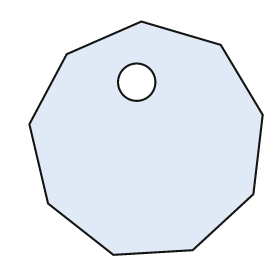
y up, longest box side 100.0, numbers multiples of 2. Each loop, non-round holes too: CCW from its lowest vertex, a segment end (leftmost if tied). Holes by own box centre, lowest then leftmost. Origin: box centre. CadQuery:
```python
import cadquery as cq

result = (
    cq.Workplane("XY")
    .moveTo(-14.0, -50.0)
    .lineTo(20.0, -48.0)
    .lineTo(46.0, -24.0)
    .lineTo(50.0, 10.0)
    .lineTo(32.0, 40.0)
    .lineTo(-2.0, 50.0)
    .lineTo(-34.0, 36.0)
    .lineTo(-50.0, 6.0)
    .lineTo(-42.0, -28.0)
    .close()
    .moveTo(-4.0, 24.0)
    .circle(8.0)
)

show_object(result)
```